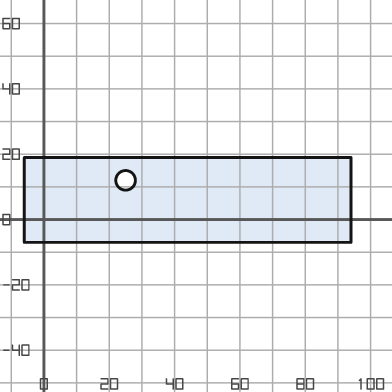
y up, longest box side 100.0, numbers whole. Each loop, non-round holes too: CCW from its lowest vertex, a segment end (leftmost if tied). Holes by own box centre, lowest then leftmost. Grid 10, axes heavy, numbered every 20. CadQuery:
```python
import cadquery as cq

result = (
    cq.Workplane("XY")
    .moveTo(-6.0, -7.0)
    .lineTo(94.0, -7.0)
    .lineTo(94.0, 19.0)
    .lineTo(-6.0, 19.0)
    .close()
    .moveTo(25.0, 12.0)
    .circle(3.0)
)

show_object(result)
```